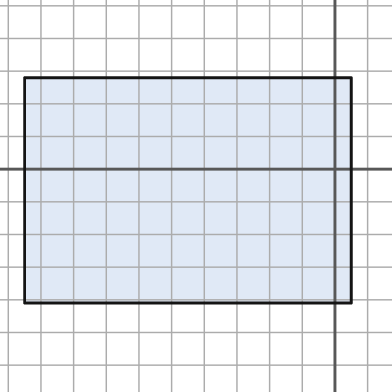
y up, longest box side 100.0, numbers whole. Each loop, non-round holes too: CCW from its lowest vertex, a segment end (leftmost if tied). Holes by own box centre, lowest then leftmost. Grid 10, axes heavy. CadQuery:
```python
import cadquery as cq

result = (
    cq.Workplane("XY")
    .moveTo(-95.0, -41.0)
    .lineTo(5.0, -41.0)
    .lineTo(5.0, 28.0)
    .lineTo(-95.0, 28.0)
    .close()
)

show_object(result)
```